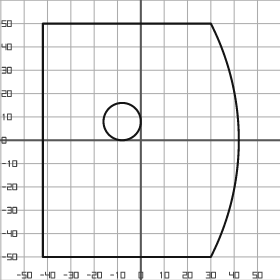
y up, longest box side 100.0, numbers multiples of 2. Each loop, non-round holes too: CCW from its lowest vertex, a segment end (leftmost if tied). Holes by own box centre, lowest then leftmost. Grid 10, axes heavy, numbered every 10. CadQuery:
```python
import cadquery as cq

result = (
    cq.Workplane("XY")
    .moveTo(-42.0, -50.0)
    .lineTo(30.0, -50.0)
    .threePointArc((42.0, 0.0), (30.0, 50.0))
    .lineTo(-42.0, 50.0)
    .close()
    .moveTo(-8.0, 8.0)
    .circle(8.0)
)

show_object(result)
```